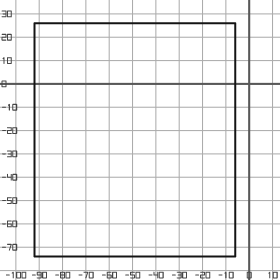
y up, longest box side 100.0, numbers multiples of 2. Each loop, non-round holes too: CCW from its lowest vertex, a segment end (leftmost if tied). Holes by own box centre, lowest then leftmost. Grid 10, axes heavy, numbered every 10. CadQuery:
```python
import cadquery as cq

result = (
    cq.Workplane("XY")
    .moveTo(-92.0, -74.0)
    .lineTo(-6.0, -74.0)
    .lineTo(-6.0, 26.0)
    .lineTo(-92.0, 26.0)
    .close()
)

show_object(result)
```